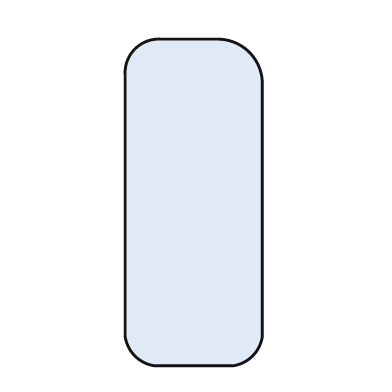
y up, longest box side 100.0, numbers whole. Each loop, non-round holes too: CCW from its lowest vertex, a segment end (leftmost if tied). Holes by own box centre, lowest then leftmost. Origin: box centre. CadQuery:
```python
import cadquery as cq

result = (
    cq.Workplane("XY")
    .moveTo(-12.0, -50.0)
    .lineTo(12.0, -50.0)
    .threePointArc((18.0, -47.0), (21.0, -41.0))
    .lineTo(21.0, 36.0)
    .threePointArc((17.0, 46.0), (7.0, 50.0))
    .lineTo(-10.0, 50.0)
    .threePointArc((-18.0, 47.0), (-21.0, 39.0))
    .lineTo(-21.0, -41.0)
    .threePointArc((-18.0, -47.0), (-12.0, -50.0))
    .close()
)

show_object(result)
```